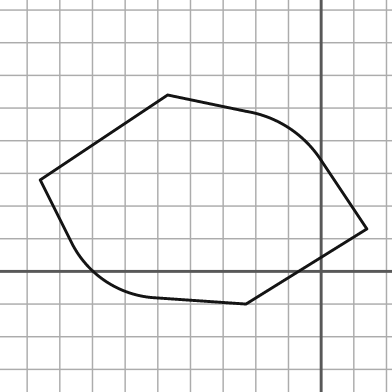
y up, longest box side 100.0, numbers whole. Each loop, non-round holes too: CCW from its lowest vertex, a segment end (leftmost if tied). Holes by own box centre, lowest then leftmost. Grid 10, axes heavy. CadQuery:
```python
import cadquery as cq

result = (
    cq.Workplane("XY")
    .moveTo(-23.0, -10.0)
    .lineTo(14.0, 13.0)
    .lineTo(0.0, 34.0)
    .threePointArc((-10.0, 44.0), (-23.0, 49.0))
    .lineTo(-47.0, 54.0)
    .lineTo(-86.0, 28.0)
    .lineTo(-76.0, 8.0)
    .threePointArc((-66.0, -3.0), (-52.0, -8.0))
    .close()
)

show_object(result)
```